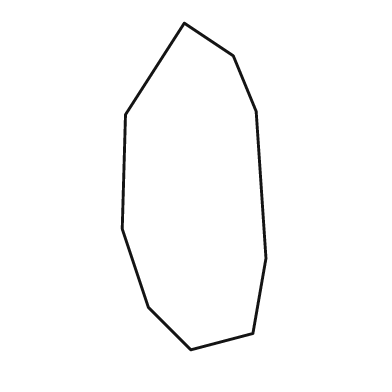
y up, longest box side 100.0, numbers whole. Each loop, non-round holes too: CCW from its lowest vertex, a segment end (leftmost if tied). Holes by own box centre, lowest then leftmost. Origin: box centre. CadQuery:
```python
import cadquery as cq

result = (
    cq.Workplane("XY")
    .moveTo(-1.0, -50.0)
    .lineTo(18.0, -45.0)
    .lineTo(22.0, -22.0)
    .lineTo(19.0, 23.0)
    .lineTo(12.0, 40.0)
    .lineTo(-3.0, 50.0)
    .lineTo(-21.0, 22.0)
    .lineTo(-22.0, -13.0)
    .lineTo(-14.0, -37.0)
    .close()
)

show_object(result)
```